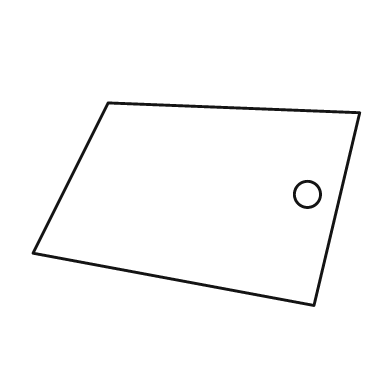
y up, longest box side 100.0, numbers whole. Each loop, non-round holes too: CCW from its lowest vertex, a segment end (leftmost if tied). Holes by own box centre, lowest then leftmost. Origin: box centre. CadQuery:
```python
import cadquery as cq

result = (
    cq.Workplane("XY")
    .moveTo(36.0, -31.0)
    .lineTo(50.0, 28.0)
    .lineTo(-27.0, 31.0)
    .lineTo(-50.0, -15.0)
    .close()
    .moveTo(34.0, 3.0)
    .circle(4.0)
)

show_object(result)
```